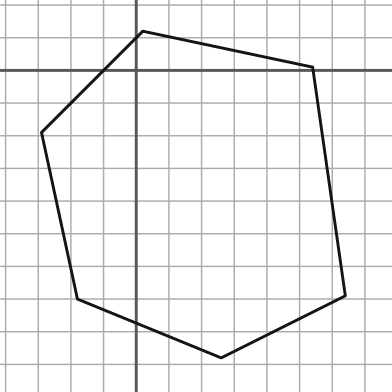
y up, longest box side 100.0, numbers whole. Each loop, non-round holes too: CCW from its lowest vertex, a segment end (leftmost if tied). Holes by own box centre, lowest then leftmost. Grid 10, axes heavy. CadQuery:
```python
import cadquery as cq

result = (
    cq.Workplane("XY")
    .moveTo(26.0, -88.0)
    .lineTo(64.0, -69.0)
    .lineTo(54.0, 1.0)
    .lineTo(2.0, 12.0)
    .lineTo(-29.0, -19.0)
    .lineTo(-18.0, -70.0)
    .close()
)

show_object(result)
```